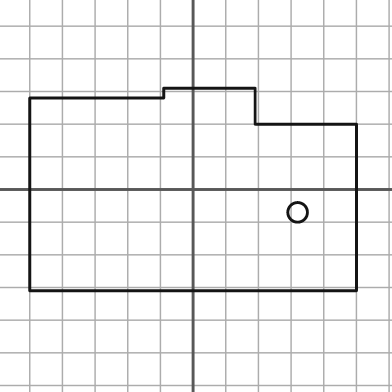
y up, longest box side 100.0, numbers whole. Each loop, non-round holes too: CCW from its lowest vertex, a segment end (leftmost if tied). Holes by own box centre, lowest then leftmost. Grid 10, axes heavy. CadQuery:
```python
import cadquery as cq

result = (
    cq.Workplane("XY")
    .moveTo(-50.0, -31.0)
    .lineTo(50.0, -31.0)
    .lineTo(50.0, 20.0)
    .lineTo(19.0, 20.0)
    .lineTo(19.0, 31.0)
    .lineTo(-9.0, 31.0)
    .lineTo(-9.0, 28.0)
    .lineTo(-50.0, 28.0)
    .close()
    .moveTo(32.0, -7.0)
    .circle(3.0)
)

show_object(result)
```